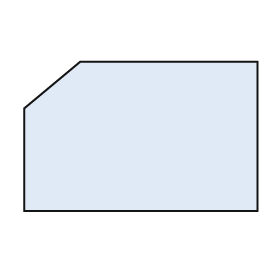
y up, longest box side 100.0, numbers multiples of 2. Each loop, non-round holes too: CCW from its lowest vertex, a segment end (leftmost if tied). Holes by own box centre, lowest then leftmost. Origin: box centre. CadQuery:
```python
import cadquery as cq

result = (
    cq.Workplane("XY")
    .moveTo(-50.0, -32.0)
    .lineTo(50.0, -32.0)
    .lineTo(50.0, 32.0)
    .lineTo(-26.0, 32.0)
    .lineTo(-50.0, 12.0)
    .close()
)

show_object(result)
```